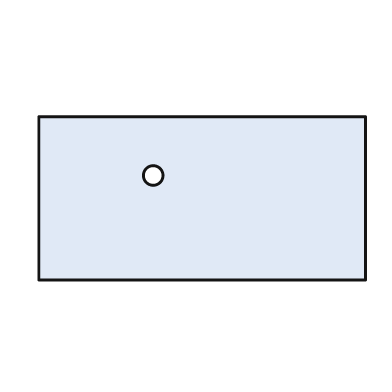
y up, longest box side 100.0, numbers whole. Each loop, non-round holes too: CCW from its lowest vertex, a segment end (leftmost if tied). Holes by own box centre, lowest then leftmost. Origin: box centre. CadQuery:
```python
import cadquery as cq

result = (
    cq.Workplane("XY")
    .moveTo(-50.0, -25.0)
    .lineTo(50.0, -25.0)
    .lineTo(50.0, 25.0)
    .lineTo(-50.0, 25.0)
    .close()
    .moveTo(-15.0, 7.0)
    .circle(3.0)
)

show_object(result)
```